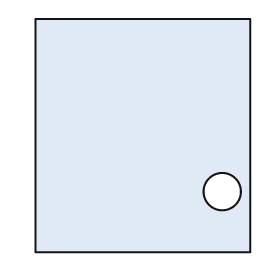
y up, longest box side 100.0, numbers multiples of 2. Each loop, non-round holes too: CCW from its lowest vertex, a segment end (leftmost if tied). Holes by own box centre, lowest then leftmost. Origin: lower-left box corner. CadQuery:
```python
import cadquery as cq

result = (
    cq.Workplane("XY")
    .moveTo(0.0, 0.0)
    .lineTo(92.0, 0.0)
    .lineTo(92.0, 100.0)
    .lineTo(0.0, 100.0)
    .close()
    .moveTo(80.0, 26.0)
    .circle(8.0)
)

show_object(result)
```